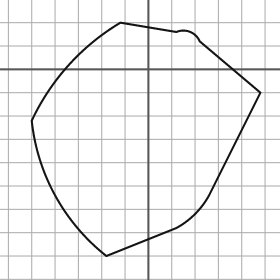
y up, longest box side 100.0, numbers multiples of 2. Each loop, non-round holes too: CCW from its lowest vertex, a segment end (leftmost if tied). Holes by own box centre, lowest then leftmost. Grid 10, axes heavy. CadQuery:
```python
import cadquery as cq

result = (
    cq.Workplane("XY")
    .moveTo(-18.0, -80.0)
    .lineTo(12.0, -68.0)
    .threePointArc((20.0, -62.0), (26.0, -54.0))
    .lineTo(48.0, -10.0)
    .lineTo(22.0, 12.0)
    .threePointArc((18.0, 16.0), (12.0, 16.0))
    .lineTo(-12.0, 20.0)
    .threePointArc((-34.0, 2.0), (-50.0, -22.0))
    .threePointArc((-40.0, -54.0), (-18.0, -80.0))
    .close()
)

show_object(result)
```